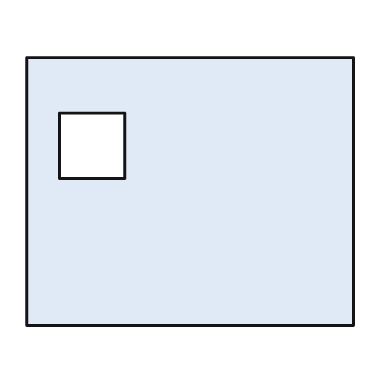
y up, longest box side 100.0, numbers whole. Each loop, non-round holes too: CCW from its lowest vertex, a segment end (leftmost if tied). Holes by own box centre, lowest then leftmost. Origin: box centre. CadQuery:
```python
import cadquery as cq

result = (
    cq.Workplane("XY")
    .moveTo(-50.0, -41.0)
    .lineTo(50.0, -41.0)
    .lineTo(50.0, 41.0)
    .lineTo(-50.0, 41.0)
    .close()
    .moveTo(-40.0, 4.0)
    .lineTo(-20.0, 4.0)
    .lineTo(-20.0, 24.0)
    .lineTo(-40.0, 24.0)
    .close()
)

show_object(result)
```